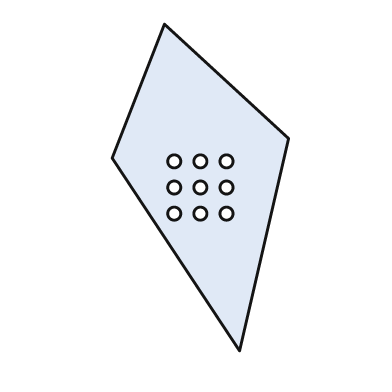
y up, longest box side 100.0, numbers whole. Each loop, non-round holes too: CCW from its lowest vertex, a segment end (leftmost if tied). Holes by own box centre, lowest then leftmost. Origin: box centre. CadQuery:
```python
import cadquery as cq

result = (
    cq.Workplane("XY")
    .moveTo(12.0, -50.0)
    .lineTo(27.0, 15.0)
    .lineTo(-11.0, 50.0)
    .lineTo(-27.0, 9.0)
    .close()
    .moveTo(-8.0, -8.0)
    .circle(2.0)
    .moveTo(0.0, -8.0)
    .circle(2.0)
    .moveTo(8.0, -8.0)
    .circle(2.0)
    .moveTo(-8.0, 0.0)
    .circle(2.0)
    .moveTo(0.0, 0.0)
    .circle(2.0)
    .moveTo(8.0, 0.0)
    .circle(2.0)
    .moveTo(-8.0, 8.0)
    .circle(2.0)
    .moveTo(0.0, 8.0)
    .circle(2.0)
    .moveTo(8.0, 8.0)
    .circle(2.0)
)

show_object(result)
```